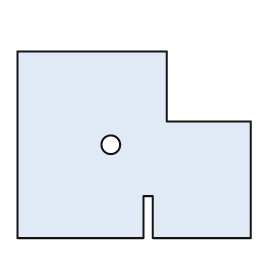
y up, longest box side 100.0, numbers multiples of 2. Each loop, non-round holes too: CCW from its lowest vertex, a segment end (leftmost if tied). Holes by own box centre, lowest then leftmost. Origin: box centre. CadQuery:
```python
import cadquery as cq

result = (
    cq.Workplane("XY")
    .moveTo(-50.0, -40.0)
    .lineTo(4.0, -40.0)
    .lineTo(4.0, -22.0)
    .lineTo(8.0, -22.0)
    .lineTo(8.0, -40.0)
    .lineTo(50.0, -40.0)
    .lineTo(50.0, 10.0)
    .lineTo(14.0, 10.0)
    .lineTo(14.0, 40.0)
    .lineTo(-50.0, 40.0)
    .close()
    .moveTo(-10.0, 0.0)
    .circle(4.0)
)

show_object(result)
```